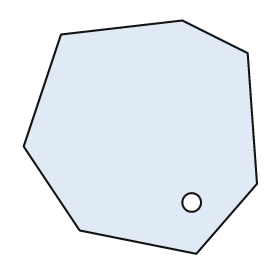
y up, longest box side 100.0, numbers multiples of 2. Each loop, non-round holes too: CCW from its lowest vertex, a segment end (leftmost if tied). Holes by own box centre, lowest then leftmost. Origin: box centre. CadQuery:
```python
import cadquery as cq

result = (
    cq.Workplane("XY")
    .moveTo(24.0, -50.0)
    .lineTo(50.0, -20.0)
    .lineTo(46.0, 36.0)
    .lineTo(18.0, 50.0)
    .lineTo(-34.0, 44.0)
    .lineTo(-50.0, -4.0)
    .lineTo(-26.0, -40.0)
    .close()
    .moveTo(22.0, -28.0)
    .circle(4.0)
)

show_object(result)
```